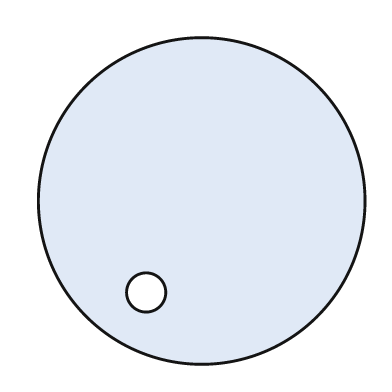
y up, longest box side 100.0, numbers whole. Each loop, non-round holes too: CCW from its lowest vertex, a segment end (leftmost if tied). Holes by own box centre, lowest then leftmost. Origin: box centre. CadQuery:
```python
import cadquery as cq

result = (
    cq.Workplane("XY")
    .moveTo(0.0, 0.0)
    .circle(50.0)
    .moveTo(-17.0, -28.0)
    .circle(6.0)
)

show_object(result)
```